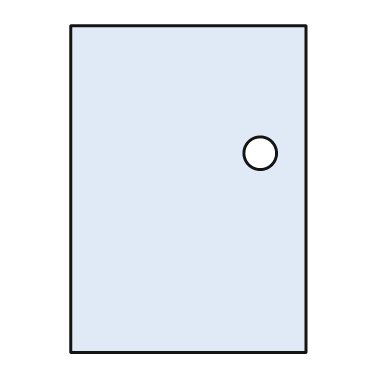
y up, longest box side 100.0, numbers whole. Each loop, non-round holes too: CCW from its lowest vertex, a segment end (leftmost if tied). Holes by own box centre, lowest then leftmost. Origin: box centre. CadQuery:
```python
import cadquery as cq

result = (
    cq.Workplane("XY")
    .moveTo(-36.0, -50.0)
    .lineTo(36.0, -50.0)
    .lineTo(36.0, 50.0)
    .lineTo(-36.0, 50.0)
    .close()
    .moveTo(22.0, 11.0)
    .circle(5.0)
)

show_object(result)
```